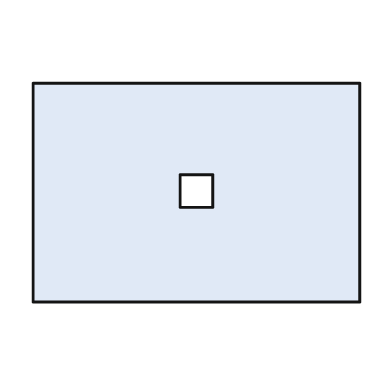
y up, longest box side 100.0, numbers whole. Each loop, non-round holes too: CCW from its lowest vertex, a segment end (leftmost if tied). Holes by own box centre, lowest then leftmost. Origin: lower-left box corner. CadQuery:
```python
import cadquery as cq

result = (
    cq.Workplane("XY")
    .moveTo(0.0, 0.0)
    .lineTo(100.0, 0.0)
    .lineTo(100.0, 67.0)
    .lineTo(0.0, 67.0)
    .close()
    .moveTo(45.0, 29.0)
    .lineTo(55.0, 29.0)
    .lineTo(55.0, 39.0)
    .lineTo(45.0, 39.0)
    .close()
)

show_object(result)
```